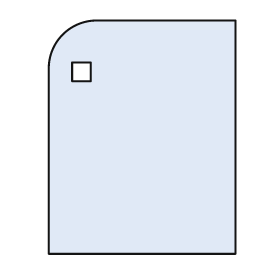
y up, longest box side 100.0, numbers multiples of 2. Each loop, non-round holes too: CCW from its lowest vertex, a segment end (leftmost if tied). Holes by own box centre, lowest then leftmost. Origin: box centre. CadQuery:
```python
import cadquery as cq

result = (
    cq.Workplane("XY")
    .moveTo(-40.0, -50.0)
    .lineTo(40.0, -50.0)
    .lineTo(40.0, 50.0)
    .lineTo(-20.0, 50.0)
    .threePointArc((-34.0, 44.0), (-40.0, 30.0))
    .close()
    .moveTo(-30.0, 24.0)
    .lineTo(-22.0, 24.0)
    .lineTo(-22.0, 32.0)
    .lineTo(-30.0, 32.0)
    .close()
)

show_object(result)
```